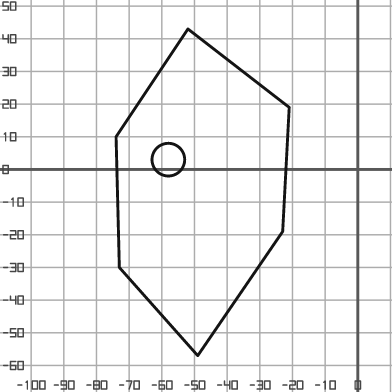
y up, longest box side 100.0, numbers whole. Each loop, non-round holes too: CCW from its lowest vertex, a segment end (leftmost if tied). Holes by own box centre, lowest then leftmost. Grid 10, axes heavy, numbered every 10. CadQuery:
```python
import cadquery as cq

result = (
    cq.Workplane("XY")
    .moveTo(-49.0, -57.0)
    .lineTo(-23.0, -19.0)
    .lineTo(-21.0, 19.0)
    .lineTo(-52.0, 43.0)
    .lineTo(-74.0, 10.0)
    .lineTo(-73.0, -30.0)
    .close()
    .moveTo(-58.0, 3.0)
    .circle(5.0)
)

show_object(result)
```